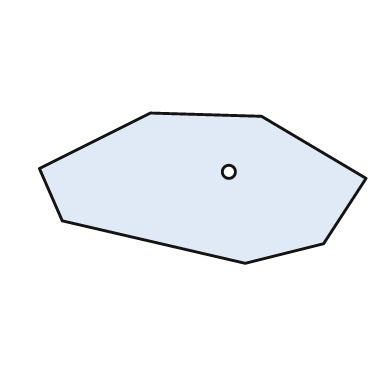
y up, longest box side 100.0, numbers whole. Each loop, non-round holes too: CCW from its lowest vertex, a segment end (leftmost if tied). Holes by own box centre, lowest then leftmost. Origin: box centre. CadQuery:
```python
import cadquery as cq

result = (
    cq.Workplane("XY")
    .moveTo(13.0, -23.0)
    .lineTo(37.0, -17.0)
    .lineTo(50.0, 3.0)
    .lineTo(18.0, 22.0)
    .lineTo(-16.0, 23.0)
    .lineTo(-50.0, 6.0)
    .lineTo(-43.0, -10.0)
    .close()
    .moveTo(8.0, 5.0)
    .circle(2.0)
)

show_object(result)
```